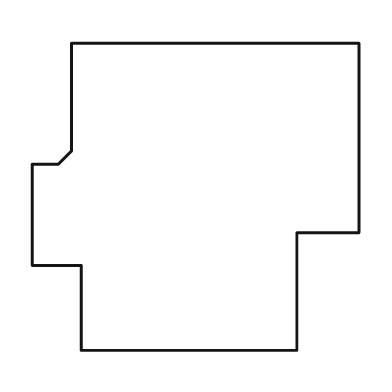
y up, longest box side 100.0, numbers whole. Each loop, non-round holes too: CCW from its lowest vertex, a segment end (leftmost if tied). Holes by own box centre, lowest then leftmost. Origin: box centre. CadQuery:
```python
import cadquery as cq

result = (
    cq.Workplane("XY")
    .moveTo(-35.0, -47.0)
    .lineTo(31.0, -47.0)
    .lineTo(31.0, -11.0)
    .lineTo(50.0, -11.0)
    .lineTo(50.0, 47.0)
    .lineTo(-38.0, 47.0)
    .lineTo(-38.0, 14.0)
    .lineTo(-42.0, 10.0)
    .lineTo(-50.0, 10.0)
    .lineTo(-50.0, -21.0)
    .lineTo(-35.0, -21.0)
    .close()
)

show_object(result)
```